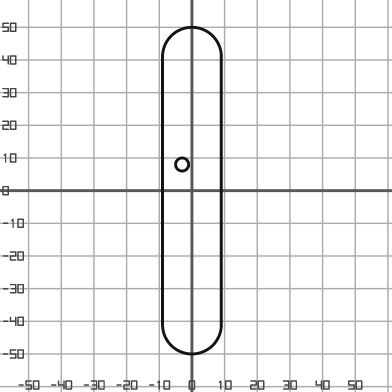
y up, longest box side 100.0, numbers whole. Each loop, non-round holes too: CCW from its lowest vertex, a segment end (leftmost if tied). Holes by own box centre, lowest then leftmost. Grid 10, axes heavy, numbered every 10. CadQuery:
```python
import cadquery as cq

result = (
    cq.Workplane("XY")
    .moveTo(-9.0, -41.0)
    .threePointArc((0.0, -50.0), (9.0, -41.0))
    .lineTo(9.0, 41.0)
    .threePointArc((0.0, 50.0), (-9.0, 41.0))
    .close()
    .moveTo(-3.0, 8.0)
    .circle(2.0)
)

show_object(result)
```